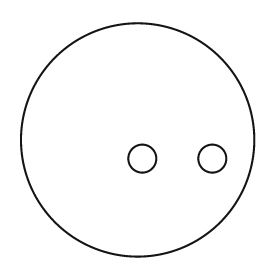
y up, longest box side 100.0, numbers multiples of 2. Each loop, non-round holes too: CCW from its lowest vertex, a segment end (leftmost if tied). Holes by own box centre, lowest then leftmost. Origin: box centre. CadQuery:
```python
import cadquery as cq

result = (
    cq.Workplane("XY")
    .moveTo(0.0, 0.0)
    .circle(50.0)
    .moveTo(2.0, -8.0)
    .circle(6.0)
    .moveTo(32.0, -8.0)
    .circle(6.0)
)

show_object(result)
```